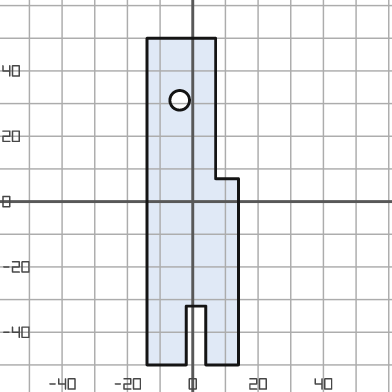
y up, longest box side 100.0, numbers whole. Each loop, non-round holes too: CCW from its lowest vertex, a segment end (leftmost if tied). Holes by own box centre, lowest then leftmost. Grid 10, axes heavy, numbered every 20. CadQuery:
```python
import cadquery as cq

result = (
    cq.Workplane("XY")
    .moveTo(-14.0, -50.0)
    .lineTo(-2.0, -50.0)
    .lineTo(-2.0, -32.0)
    .lineTo(4.0, -32.0)
    .lineTo(4.0, -50.0)
    .lineTo(14.0, -50.0)
    .lineTo(14.0, 7.0)
    .lineTo(7.0, 7.0)
    .lineTo(7.0, 50.0)
    .lineTo(-14.0, 50.0)
    .close()
    .moveTo(-4.0, 31.0)
    .circle(3.0)
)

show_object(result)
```